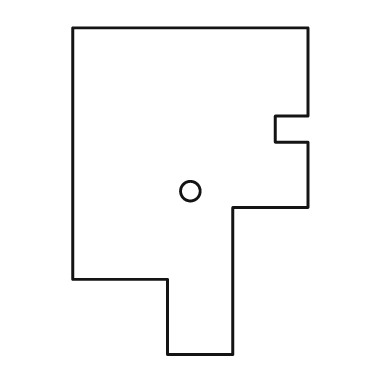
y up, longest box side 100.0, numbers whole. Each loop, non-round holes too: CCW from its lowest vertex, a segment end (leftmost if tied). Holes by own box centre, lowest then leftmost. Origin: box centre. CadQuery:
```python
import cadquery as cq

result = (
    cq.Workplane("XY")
    .moveTo(-7.0, -50.0)
    .lineTo(13.0, -50.0)
    .lineTo(13.0, -5.0)
    .lineTo(36.0, -5.0)
    .lineTo(36.0, 15.0)
    .lineTo(26.0, 15.0)
    .lineTo(26.0, 23.0)
    .lineTo(36.0, 23.0)
    .lineTo(36.0, 50.0)
    .lineTo(-36.0, 50.0)
    .lineTo(-36.0, -27.0)
    .lineTo(-7.0, -27.0)
    .close()
    .moveTo(0.0, 0.0)
    .circle(3.0)
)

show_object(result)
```